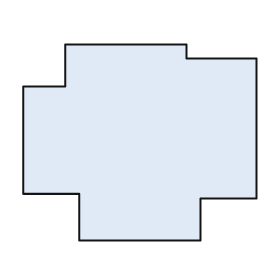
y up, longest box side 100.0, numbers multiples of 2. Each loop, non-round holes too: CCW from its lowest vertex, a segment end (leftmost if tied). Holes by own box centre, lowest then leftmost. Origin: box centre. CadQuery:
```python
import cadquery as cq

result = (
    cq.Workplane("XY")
    .moveTo(-26.0, -42.0)
    .lineTo(26.0, -42.0)
    .lineTo(26.0, -24.0)
    .lineTo(50.0, -24.0)
    .lineTo(50.0, 36.0)
    .lineTo(20.0, 36.0)
    .lineTo(20.0, 42.0)
    .lineTo(-32.0, 42.0)
    .lineTo(-32.0, 24.0)
    .lineTo(-50.0, 24.0)
    .lineTo(-50.0, -22.0)
    .lineTo(-26.0, -22.0)
    .close()
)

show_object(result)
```